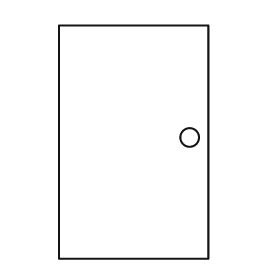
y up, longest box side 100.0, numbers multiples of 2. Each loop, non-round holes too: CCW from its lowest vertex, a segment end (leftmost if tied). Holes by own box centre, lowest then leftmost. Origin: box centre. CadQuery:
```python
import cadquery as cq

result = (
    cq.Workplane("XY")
    .moveTo(-32.0, -50.0)
    .lineTo(32.0, -50.0)
    .lineTo(32.0, 50.0)
    .lineTo(-32.0, 50.0)
    .close()
    .moveTo(24.0, 2.0)
    .circle(4.0)
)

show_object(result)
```